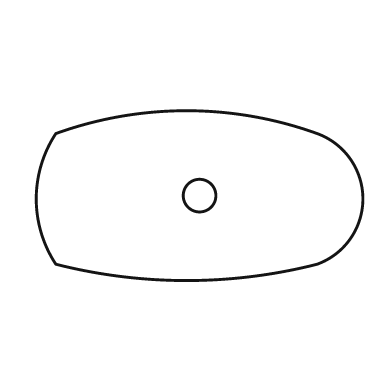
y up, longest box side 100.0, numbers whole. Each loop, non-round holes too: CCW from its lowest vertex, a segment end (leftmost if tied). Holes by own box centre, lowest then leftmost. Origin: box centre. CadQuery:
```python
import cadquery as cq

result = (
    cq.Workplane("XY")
    .moveTo(-44.0, -21.0)
    .threePointArc((-4.0, -26.0), (36.0, -21.0))
    .threePointArc((50.0, -1.0), (36.0, 19.0))
    .threePointArc((-4.0, 26.0), (-44.0, 19.0))
    .threePointArc((-50.0, -1.0), (-44.0, -21.0))
    .close()
    .moveTo(0.0, 0.0)
    .circle(5.0)
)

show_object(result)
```